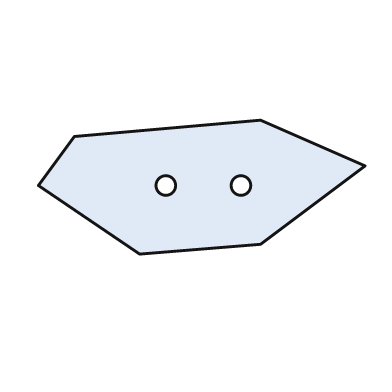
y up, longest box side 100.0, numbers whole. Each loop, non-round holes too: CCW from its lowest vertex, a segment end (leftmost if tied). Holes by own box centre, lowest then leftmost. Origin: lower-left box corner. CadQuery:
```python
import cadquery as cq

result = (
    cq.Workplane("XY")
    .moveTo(31.0, 0.0)
    .lineTo(68.0, 3.0)
    .lineTo(100.0, 27.0)
    .lineTo(68.0, 41.0)
    .lineTo(11.0, 36.0)
    .lineTo(0.0, 21.0)
    .close()
    .moveTo(39.0, 21.0)
    .circle(3.0)
    .moveTo(62.0, 21.0)
    .circle(3.0)
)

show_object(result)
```